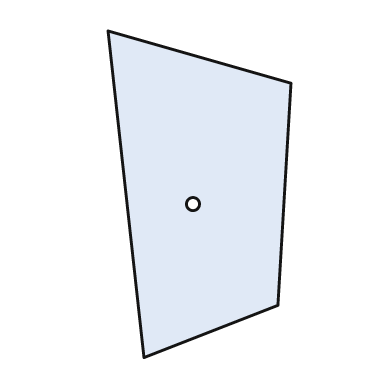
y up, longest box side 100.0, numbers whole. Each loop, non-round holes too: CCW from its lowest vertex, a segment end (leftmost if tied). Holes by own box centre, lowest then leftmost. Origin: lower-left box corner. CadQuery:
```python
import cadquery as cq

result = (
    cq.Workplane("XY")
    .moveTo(11.0, 0.0)
    .lineTo(52.0, 16.0)
    .lineTo(56.0, 84.0)
    .lineTo(0.0, 100.0)
    .close()
    .moveTo(26.0, 47.0)
    .circle(2.0)
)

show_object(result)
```